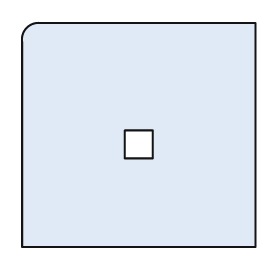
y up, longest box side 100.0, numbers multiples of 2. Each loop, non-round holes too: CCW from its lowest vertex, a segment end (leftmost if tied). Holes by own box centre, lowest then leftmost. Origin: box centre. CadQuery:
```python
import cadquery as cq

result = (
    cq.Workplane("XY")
    .moveTo(-50.0, -48.0)
    .lineTo(50.0, -48.0)
    .lineTo(50.0, 48.0)
    .lineTo(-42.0, 48.0)
    .threePointArc((-48.0, 46.0), (-50.0, 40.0))
    .close()
    .moveTo(-6.0, -10.0)
    .lineTo(6.0, -10.0)
    .lineTo(6.0, 2.0)
    .lineTo(-6.0, 2.0)
    .close()
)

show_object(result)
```